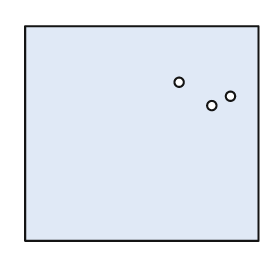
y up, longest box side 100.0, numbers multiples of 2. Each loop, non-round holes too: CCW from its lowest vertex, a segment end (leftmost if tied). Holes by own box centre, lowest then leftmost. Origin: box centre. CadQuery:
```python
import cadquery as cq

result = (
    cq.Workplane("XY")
    .moveTo(-50.0, -46.0)
    .lineTo(50.0, -46.0)
    .lineTo(50.0, 46.0)
    .lineTo(-50.0, 46.0)
    .close()
    .moveTo(30.0, 12.0)
    .circle(2.0)
    .moveTo(38.0, 16.0)
    .circle(2.0)
    .moveTo(16.0, 22.0)
    .circle(2.0)
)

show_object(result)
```